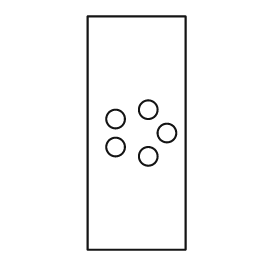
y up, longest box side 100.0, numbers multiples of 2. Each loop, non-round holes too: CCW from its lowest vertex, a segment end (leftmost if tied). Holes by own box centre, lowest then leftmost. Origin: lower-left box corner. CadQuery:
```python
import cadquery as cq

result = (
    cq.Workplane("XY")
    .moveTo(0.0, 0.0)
    .lineTo(42.0, 0.0)
    .lineTo(42.0, 100.0)
    .lineTo(0.0, 100.0)
    .close()
    .moveTo(26.0, 40.0)
    .circle(4.0)
    .moveTo(12.0, 44.0)
    .circle(4.0)
    .moveTo(34.0, 50.0)
    .circle(4.0)
    .moveTo(12.0, 56.0)
    .circle(4.0)
    .moveTo(26.0, 60.0)
    .circle(4.0)
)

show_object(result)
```